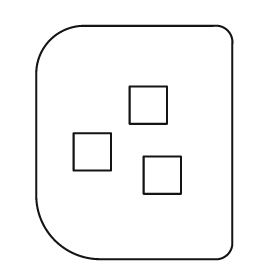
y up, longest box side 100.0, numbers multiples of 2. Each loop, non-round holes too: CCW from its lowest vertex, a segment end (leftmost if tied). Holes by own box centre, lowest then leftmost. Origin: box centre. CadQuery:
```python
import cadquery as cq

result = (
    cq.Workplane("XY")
    .moveTo(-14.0, -50.0)
    .lineTo(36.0, -50.0)
    .threePointArc((40.0, -48.0), (42.0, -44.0))
    .lineTo(42.0, 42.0)
    .threePointArc((40.0, 48.0), (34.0, 50.0))
    .lineTo(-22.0, 50.0)
    .threePointArc((-36.0, 44.0), (-42.0, 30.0))
    .lineTo(-42.0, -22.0)
    .threePointArc((-34.0, -42.0), (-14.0, -50.0))
    .close()
    .moveTo(4.0, -22.0)
    .lineTo(20.0, -22.0)
    .lineTo(20.0, -6.0)
    .lineTo(4.0, -6.0)
    .close()
    .moveTo(-26.0, -12.0)
    .lineTo(-10.0, -12.0)
    .lineTo(-10.0, 4.0)
    .lineTo(-26.0, 4.0)
    .close()
    .moveTo(-2.0, 8.0)
    .lineTo(14.0, 8.0)
    .lineTo(14.0, 24.0)
    .lineTo(-2.0, 24.0)
    .close()
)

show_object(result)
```